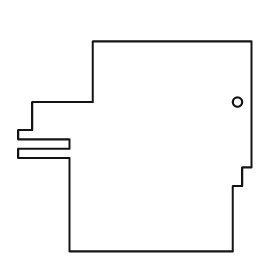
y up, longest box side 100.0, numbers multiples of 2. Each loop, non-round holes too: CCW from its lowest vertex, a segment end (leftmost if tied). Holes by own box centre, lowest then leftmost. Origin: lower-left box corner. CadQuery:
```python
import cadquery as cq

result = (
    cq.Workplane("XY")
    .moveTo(22.0, 0.0)
    .lineTo(92.0, 0.0)
    .lineTo(92.0, 28.0)
    .lineTo(96.0, 28.0)
    .lineTo(96.0, 36.0)
    .lineTo(100.0, 36.0)
    .lineTo(100.0, 90.0)
    .lineTo(32.0, 90.0)
    .lineTo(32.0, 64.0)
    .lineTo(6.0, 64.0)
    .lineTo(6.0, 52.0)
    .lineTo(0.0, 52.0)
    .lineTo(0.0, 48.0)
    .lineTo(22.0, 48.0)
    .lineTo(22.0, 44.0)
    .lineTo(0.0, 44.0)
    .lineTo(0.0, 40.0)
    .lineTo(22.0, 40.0)
    .close()
    .moveTo(94.0, 64.0)
    .circle(2.0)
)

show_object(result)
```